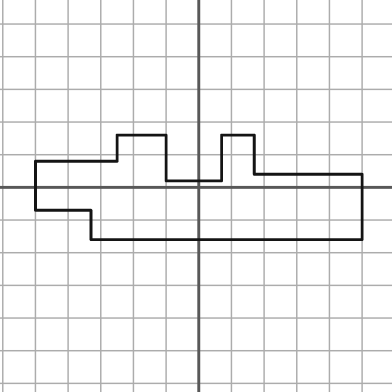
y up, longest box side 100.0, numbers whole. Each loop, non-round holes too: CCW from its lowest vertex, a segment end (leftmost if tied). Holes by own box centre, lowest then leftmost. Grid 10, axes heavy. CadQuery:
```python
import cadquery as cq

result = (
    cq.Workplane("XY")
    .moveTo(-33.0, -16.0)
    .lineTo(50.0, -16.0)
    .lineTo(50.0, 4.0)
    .lineTo(17.0, 4.0)
    .lineTo(17.0, 16.0)
    .lineTo(7.0, 16.0)
    .lineTo(7.0, 2.0)
    .lineTo(-10.0, 2.0)
    .lineTo(-10.0, 16.0)
    .lineTo(-25.0, 16.0)
    .lineTo(-25.0, 8.0)
    .lineTo(-50.0, 8.0)
    .lineTo(-50.0, -7.0)
    .lineTo(-33.0, -7.0)
    .close()
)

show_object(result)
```